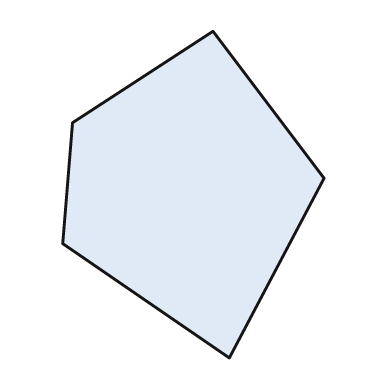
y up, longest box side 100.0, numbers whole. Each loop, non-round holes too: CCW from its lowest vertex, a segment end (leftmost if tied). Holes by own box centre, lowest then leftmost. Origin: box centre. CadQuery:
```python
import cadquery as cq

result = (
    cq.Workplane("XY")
    .moveTo(11.0, -50.0)
    .lineTo(40.0, 5.0)
    .lineTo(6.0, 50.0)
    .lineTo(-37.0, 22.0)
    .lineTo(-40.0, -15.0)
    .close()
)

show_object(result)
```